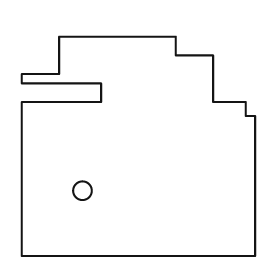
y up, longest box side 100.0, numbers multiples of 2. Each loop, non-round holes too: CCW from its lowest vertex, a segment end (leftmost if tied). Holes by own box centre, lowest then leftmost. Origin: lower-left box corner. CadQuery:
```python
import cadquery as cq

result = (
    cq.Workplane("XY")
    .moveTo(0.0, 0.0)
    .lineTo(100.0, 0.0)
    .lineTo(100.0, 60.0)
    .lineTo(96.0, 60.0)
    .lineTo(96.0, 66.0)
    .lineTo(82.0, 66.0)
    .lineTo(82.0, 86.0)
    .lineTo(66.0, 86.0)
    .lineTo(66.0, 94.0)
    .lineTo(16.0, 94.0)
    .lineTo(16.0, 78.0)
    .lineTo(0.0, 78.0)
    .lineTo(0.0, 74.0)
    .lineTo(34.0, 74.0)
    .lineTo(34.0, 66.0)
    .lineTo(0.0, 66.0)
    .close()
    .moveTo(26.0, 28.0)
    .circle(4.0)
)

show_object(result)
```